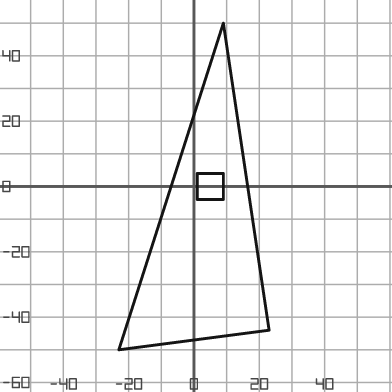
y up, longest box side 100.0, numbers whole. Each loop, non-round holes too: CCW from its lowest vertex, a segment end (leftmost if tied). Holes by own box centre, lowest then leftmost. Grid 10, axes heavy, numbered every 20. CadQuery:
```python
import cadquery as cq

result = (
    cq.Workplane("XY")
    .moveTo(-23.0, -50.0)
    .lineTo(23.0, -44.0)
    .lineTo(9.0, 50.0)
    .close()
    .moveTo(1.0, -4.0)
    .lineTo(9.0, -4.0)
    .lineTo(9.0, 4.0)
    .lineTo(1.0, 4.0)
    .close()
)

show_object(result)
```